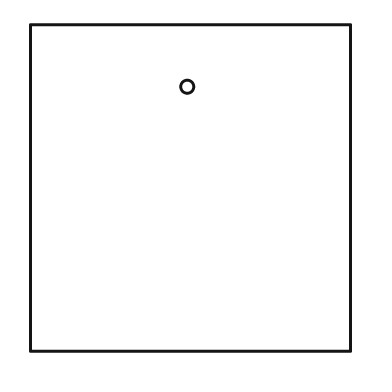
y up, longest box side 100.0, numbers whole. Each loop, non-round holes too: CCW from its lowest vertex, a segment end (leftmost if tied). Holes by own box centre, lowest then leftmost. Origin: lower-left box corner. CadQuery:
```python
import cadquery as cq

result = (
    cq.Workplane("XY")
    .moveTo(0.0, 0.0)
    .lineTo(98.0, 0.0)
    .lineTo(98.0, 100.0)
    .lineTo(0.0, 100.0)
    .close()
    .moveTo(48.0, 81.0)
    .circle(2.0)
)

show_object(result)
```